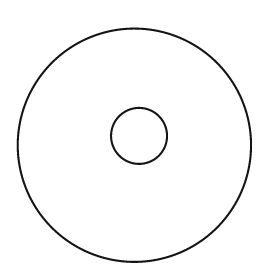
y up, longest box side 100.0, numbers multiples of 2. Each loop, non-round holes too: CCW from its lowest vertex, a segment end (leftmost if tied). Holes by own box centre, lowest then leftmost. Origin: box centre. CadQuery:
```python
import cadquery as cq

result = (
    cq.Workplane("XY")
    .moveTo(0.0, 0.0)
    .circle(50.0)
    .moveTo(2.0, 4.0)
    .circle(12.0)
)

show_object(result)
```